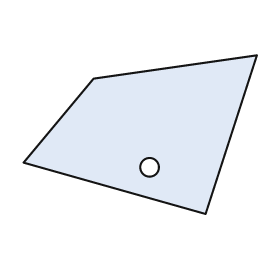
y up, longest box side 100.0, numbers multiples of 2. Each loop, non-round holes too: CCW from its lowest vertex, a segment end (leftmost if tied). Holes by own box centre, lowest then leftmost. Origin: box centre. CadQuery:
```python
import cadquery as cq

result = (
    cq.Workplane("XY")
    .moveTo(28.0, -34.0)
    .lineTo(50.0, 34.0)
    .lineTo(-20.0, 24.0)
    .lineTo(-50.0, -12.0)
    .close()
    .moveTo(4.0, -14.0)
    .circle(4.0)
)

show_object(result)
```